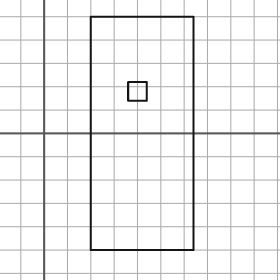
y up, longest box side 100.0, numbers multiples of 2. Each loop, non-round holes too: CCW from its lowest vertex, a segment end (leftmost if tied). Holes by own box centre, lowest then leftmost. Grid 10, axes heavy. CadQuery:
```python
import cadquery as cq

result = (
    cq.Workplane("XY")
    .moveTo(20.0, -50.0)
    .lineTo(64.0, -50.0)
    .lineTo(64.0, 50.0)
    .lineTo(20.0, 50.0)
    .close()
    .moveTo(36.0, 14.0)
    .lineTo(44.0, 14.0)
    .lineTo(44.0, 22.0)
    .lineTo(36.0, 22.0)
    .close()
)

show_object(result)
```